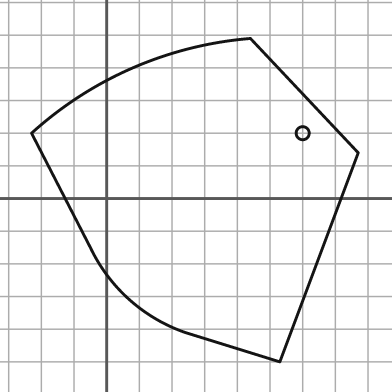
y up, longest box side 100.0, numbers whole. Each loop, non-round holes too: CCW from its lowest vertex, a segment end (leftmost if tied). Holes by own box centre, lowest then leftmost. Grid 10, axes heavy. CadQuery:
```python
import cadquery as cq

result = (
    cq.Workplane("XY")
    .moveTo(53.0, -50.0)
    .lineTo(77.0, 14.0)
    .lineTo(44.0, 49.0)
    .threePointArc((8.0, 40.0), (-23.0, 20.0))
    .lineTo(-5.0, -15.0)
    .threePointArc((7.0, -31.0), (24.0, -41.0))
    .close()
    .moveTo(60.0, 20.0)
    .circle(2.0)
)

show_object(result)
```